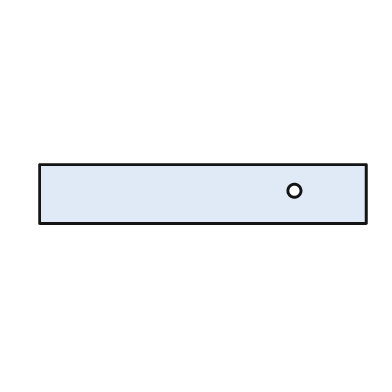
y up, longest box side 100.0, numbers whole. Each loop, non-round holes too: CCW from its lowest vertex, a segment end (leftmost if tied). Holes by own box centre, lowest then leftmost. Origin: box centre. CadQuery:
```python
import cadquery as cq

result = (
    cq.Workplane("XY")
    .moveTo(-50.0, -9.0)
    .lineTo(50.0, -9.0)
    .lineTo(50.0, 9.0)
    .lineTo(-50.0, 9.0)
    .close()
    .moveTo(28.0, 1.0)
    .circle(2.0)
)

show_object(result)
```